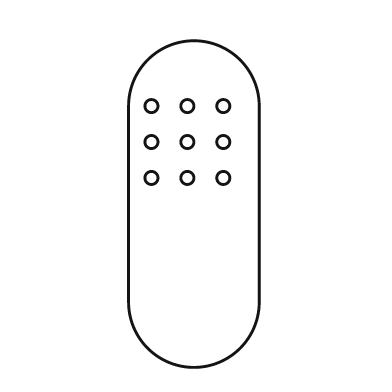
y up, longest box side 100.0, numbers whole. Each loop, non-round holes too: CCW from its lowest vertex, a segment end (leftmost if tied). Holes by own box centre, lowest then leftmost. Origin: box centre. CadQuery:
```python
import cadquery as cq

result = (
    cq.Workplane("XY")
    .moveTo(-20.0, -30.0)
    .threePointArc((0.0, -50.0), (20.0, -30.0))
    .lineTo(20.0, 30.0)
    .threePointArc((0.0, 50.0), (-20.0, 30.0))
    .close()
    .moveTo(-13.0, 8.0)
    .circle(2.0)
    .moveTo(-2.0, 8.0)
    .circle(2.0)
    .moveTo(9.0, 8.0)
    .circle(2.0)
    .moveTo(-13.0, 19.0)
    .circle(2.0)
    .moveTo(-2.0, 19.0)
    .circle(2.0)
    .moveTo(9.0, 19.0)
    .circle(2.0)
    .moveTo(-13.0, 30.0)
    .circle(2.0)
    .moveTo(-2.0, 30.0)
    .circle(2.0)
    .moveTo(9.0, 30.0)
    .circle(2.0)
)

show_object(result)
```